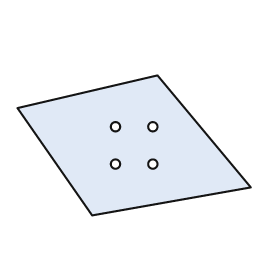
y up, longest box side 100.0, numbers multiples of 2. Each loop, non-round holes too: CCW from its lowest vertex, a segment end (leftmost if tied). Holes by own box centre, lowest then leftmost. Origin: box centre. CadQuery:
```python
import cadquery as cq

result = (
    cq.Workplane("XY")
    .moveTo(-18.0, -30.0)
    .lineTo(50.0, -18.0)
    .lineTo(10.0, 30.0)
    .lineTo(-50.0, 16.0)
    .close()
    .moveTo(-8.0, -8.0)
    .circle(2.0)
    .moveTo(8.0, -8.0)
    .circle(2.0)
    .moveTo(-8.0, 8.0)
    .circle(2.0)
    .moveTo(8.0, 8.0)
    .circle(2.0)
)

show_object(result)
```